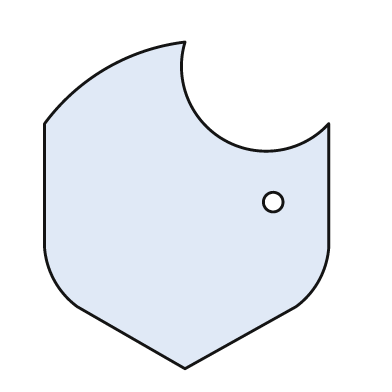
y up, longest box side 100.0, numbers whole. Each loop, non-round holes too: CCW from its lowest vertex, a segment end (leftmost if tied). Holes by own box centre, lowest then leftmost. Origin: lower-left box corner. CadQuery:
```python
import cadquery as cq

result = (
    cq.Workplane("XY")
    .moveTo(43.0, 0.0)
    .lineTo(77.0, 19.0)
    .threePointArc((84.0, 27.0), (87.0, 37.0))
    .lineTo(87.0, 75.0)
    .threePointArc((55.0, 70.0), (43.0, 100.0))
    .threePointArc((19.0, 92.0), (0.0, 75.0))
    .lineTo(0.0, 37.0)
    .threePointArc((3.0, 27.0), (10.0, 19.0))
    .close()
    .moveTo(70.0, 51.0)
    .circle(3.0)
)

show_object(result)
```